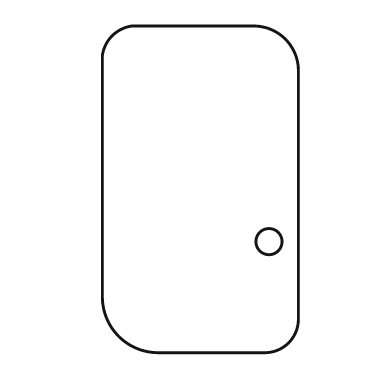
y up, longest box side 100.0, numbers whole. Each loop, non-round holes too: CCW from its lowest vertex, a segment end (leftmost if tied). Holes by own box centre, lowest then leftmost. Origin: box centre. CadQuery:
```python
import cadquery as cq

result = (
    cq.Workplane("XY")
    .moveTo(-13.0, -50.0)
    .lineTo(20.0, -50.0)
    .threePointArc((27.0, -47.0), (30.0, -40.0))
    .lineTo(30.0, 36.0)
    .threePointArc((26.0, 46.0), (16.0, 50.0))
    .lineTo(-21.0, 50.0)
    .threePointArc((-27.0, 47.0), (-30.0, 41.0))
    .lineTo(-30.0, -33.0)
    .threePointArc((-25.0, -45.0), (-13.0, -50.0))
    .close()
    .moveTo(21.0, -16.0)
    .circle(4.0)
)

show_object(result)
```